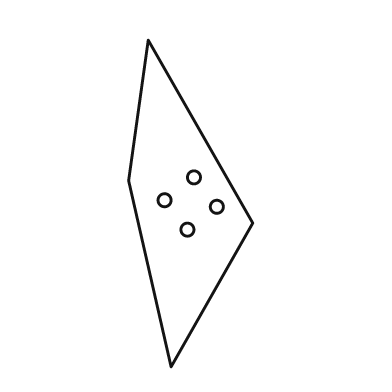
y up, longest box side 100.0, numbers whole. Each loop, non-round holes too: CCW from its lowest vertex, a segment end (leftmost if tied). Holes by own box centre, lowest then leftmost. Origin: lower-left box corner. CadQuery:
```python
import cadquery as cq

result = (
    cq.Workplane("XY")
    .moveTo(13.0, 0.0)
    .lineTo(38.0, 44.0)
    .lineTo(6.0, 100.0)
    .lineTo(0.0, 57.0)
    .close()
    .moveTo(18.0, 42.0)
    .circle(2.0)
    .moveTo(27.0, 49.0)
    .circle(2.0)
    .moveTo(11.0, 51.0)
    .circle(2.0)
    .moveTo(20.0, 58.0)
    .circle(2.0)
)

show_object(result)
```